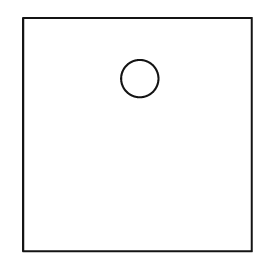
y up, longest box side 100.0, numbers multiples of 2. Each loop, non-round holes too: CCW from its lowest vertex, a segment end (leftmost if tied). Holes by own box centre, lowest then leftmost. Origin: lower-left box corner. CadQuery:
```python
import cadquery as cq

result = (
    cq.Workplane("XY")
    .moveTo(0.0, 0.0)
    .lineTo(98.0, 0.0)
    .lineTo(98.0, 100.0)
    .lineTo(0.0, 100.0)
    .close()
    .moveTo(50.0, 74.0)
    .circle(8.0)
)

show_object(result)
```